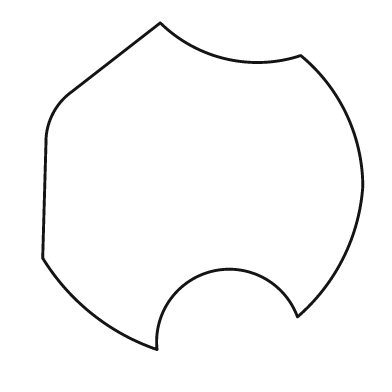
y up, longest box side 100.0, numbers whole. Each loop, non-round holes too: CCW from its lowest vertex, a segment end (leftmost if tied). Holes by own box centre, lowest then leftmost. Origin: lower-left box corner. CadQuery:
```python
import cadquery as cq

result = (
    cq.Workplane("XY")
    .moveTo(35.0, 0.0)
    .threePointArc((52.0, 24.0), (78.0, 10.0))
    .threePointArc((92.0, 28.0), (98.0, 50.0))
    .threePointArc((93.0, 72.0), (79.0, 90.0))
    .threePointArc((56.0, 89.0), (36.0, 100.0))
    .lineTo(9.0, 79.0)
    .threePointArc((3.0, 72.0), (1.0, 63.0))
    .lineTo(0.0, 28.0)
    .threePointArc((15.0, 11.0), (35.0, 0.0))
    .close()
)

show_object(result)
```